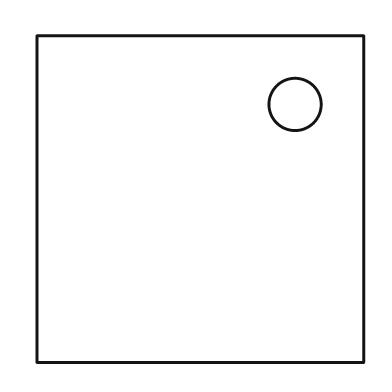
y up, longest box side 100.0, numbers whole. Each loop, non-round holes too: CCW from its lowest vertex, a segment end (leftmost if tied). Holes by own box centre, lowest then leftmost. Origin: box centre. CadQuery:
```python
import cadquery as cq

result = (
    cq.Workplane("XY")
    .moveTo(-50.0, -50.0)
    .lineTo(50.0, -50.0)
    .lineTo(50.0, 50.0)
    .lineTo(-50.0, 50.0)
    .close()
    .moveTo(29.0, 29.0)
    .circle(8.0)
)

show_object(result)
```